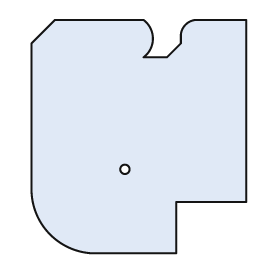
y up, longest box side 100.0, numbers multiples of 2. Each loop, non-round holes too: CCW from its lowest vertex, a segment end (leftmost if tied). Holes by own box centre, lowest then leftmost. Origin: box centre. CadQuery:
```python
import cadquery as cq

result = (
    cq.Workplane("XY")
    .moveTo(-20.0, -50.0)
    .lineTo(16.0, -50.0)
    .lineTo(16.0, -28.0)
    .lineTo(46.0, -28.0)
    .lineTo(46.0, 50.0)
    .lineTo(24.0, 50.0)
    .threePointArc((20.0, 48.0), (18.0, 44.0))
    .lineTo(18.0, 40.0)
    .lineTo(12.0, 34.0)
    .lineTo(2.0, 34.0)
    .threePointArc((6.0, 42.0), (2.0, 50.0))
    .lineTo(-36.0, 50.0)
    .lineTo(-46.0, 40.0)
    .lineTo(-46.0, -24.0)
    .threePointArc((-38.0, -42.0), (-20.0, -50.0))
    .close()
    .moveTo(-6.0, -14.0)
    .circle(2.0)
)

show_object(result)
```